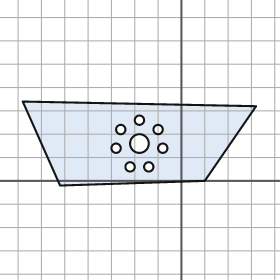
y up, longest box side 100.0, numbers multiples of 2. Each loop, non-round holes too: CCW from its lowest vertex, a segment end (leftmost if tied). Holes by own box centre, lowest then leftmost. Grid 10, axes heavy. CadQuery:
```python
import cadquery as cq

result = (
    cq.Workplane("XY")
    .moveTo(-52.0, -2.0)
    .lineTo(10.0, 0.0)
    .lineTo(32.0, 32.0)
    .lineTo(-68.0, 34.0)
    .close()
    .moveTo(-22.0, 6.0)
    .circle(2.0)
    .moveTo(-14.0, 6.0)
    .circle(2.0)
    .moveTo(-28.0, 14.0)
    .circle(2.0)
    .moveTo(-8.0, 14.0)
    .circle(2.0)
    .moveTo(-18.0, 16.0)
    .circle(4.0)
    .moveTo(-26.0, 22.0)
    .circle(2.0)
    .moveTo(-10.0, 22.0)
    .circle(2.0)
    .moveTo(-18.0, 26.0)
    .circle(2.0)
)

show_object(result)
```